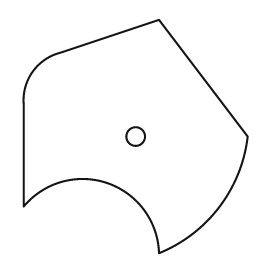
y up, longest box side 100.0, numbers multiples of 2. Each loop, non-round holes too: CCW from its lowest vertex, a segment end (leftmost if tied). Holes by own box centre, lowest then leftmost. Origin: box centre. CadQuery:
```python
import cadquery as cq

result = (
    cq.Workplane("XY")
    .moveTo(10.0, -50.0)
    .threePointArc((36.0, -30.0), (48.0, 0.0))
    .lineTo(10.0, 50.0)
    .lineTo(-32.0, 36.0)
    .threePointArc((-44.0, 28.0), (-48.0, 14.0))
    .lineTo(-48.0, -30.0)
    .threePointArc((-12.0, -20.0), (10.0, -50.0))
    .close()
    .moveTo(0.0, 0.0)
    .circle(4.0)
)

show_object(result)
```